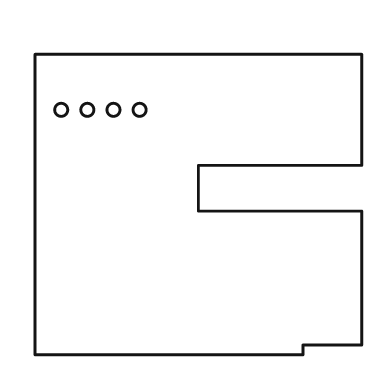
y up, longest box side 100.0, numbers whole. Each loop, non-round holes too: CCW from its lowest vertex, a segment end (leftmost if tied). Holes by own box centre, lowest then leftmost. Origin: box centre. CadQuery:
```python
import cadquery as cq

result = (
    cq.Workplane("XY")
    .moveTo(-50.0, -46.0)
    .lineTo(32.0, -46.0)
    .lineTo(32.0, -43.0)
    .lineTo(50.0, -43.0)
    .lineTo(50.0, -2.0)
    .lineTo(0.0, -2.0)
    .lineTo(0.0, 12.0)
    .lineTo(50.0, 12.0)
    .lineTo(50.0, 46.0)
    .lineTo(-50.0, 46.0)
    .close()
    .moveTo(-42.0, 29.0)
    .circle(2.0)
    .moveTo(-34.0, 29.0)
    .circle(2.0)
    .moveTo(-26.0, 29.0)
    .circle(2.0)
    .moveTo(-18.0, 29.0)
    .circle(2.0)
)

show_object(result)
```